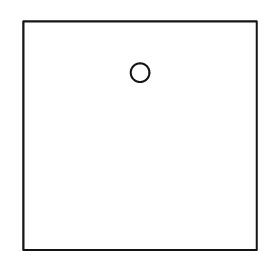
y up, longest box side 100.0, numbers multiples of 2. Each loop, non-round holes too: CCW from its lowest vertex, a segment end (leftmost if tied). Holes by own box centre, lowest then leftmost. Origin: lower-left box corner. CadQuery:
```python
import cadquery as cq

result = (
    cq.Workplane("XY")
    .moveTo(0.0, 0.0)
    .lineTo(100.0, 0.0)
    .lineTo(100.0, 98.0)
    .lineTo(0.0, 98.0)
    .close()
    .moveTo(50.0, 76.0)
    .circle(4.0)
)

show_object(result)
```